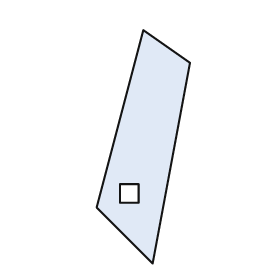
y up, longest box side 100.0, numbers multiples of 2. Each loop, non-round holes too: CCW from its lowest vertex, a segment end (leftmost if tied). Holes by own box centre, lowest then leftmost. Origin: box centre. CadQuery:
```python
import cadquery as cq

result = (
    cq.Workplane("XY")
    .moveTo(4.0, -50.0)
    .lineTo(20.0, 36.0)
    .lineTo(0.0, 50.0)
    .lineTo(-20.0, -26.0)
    .close()
    .moveTo(-10.0, -24.0)
    .lineTo(-2.0, -24.0)
    .lineTo(-2.0, -16.0)
    .lineTo(-10.0, -16.0)
    .close()
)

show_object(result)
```